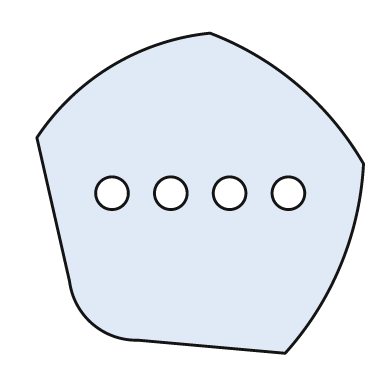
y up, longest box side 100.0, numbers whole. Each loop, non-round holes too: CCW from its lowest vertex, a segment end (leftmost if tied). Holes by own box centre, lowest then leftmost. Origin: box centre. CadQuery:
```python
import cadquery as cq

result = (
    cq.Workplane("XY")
    .moveTo(26.0, -49.0)
    .threePointArc((43.0, -22.0), (50.0, 9.0))
    .threePointArc((30.0, 33.0), (3.0, 49.0))
    .threePointArc((-27.0, 39.0), (-50.0, 17.0))
    .lineTo(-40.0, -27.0)
    .threePointArc((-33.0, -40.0), (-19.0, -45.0))
    .close()
    .moveTo(-27.0, 0.0)
    .circle(5.0)
    .moveTo(-9.0, 0.0)
    .circle(5.0)
    .moveTo(9.0, 0.0)
    .circle(5.0)
    .moveTo(27.0, 0.0)
    .circle(5.0)
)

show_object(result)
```